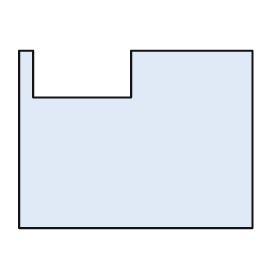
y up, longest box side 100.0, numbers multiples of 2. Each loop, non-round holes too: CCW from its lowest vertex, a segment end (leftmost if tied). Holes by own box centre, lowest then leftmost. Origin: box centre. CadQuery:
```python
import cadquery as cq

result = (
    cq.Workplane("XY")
    .moveTo(-50.0, -38.0)
    .lineTo(50.0, -38.0)
    .lineTo(50.0, 38.0)
    .lineTo(-2.0, 38.0)
    .lineTo(-2.0, 18.0)
    .lineTo(-44.0, 18.0)
    .lineTo(-44.0, 38.0)
    .lineTo(-50.0, 38.0)
    .close()
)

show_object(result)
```